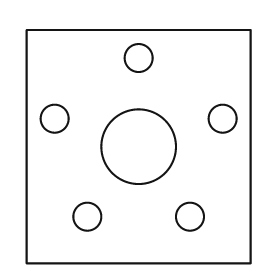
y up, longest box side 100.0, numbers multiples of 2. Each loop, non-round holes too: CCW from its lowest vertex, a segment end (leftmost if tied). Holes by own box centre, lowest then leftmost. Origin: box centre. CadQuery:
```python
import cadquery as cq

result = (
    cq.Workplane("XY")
    .moveTo(-48.0, -50.0)
    .lineTo(48.0, -50.0)
    .lineTo(48.0, 50.0)
    .lineTo(-48.0, 50.0)
    .close()
    .moveTo(-22.0, -30.0)
    .circle(6.0)
    .moveTo(22.0, -30.0)
    .circle(6.0)
    .moveTo(0.0, 0.0)
    .circle(16.0)
    .moveTo(-36.0, 12.0)
    .circle(6.0)
    .moveTo(36.0, 12.0)
    .circle(6.0)
    .moveTo(0.0, 38.0)
    .circle(6.0)
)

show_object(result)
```